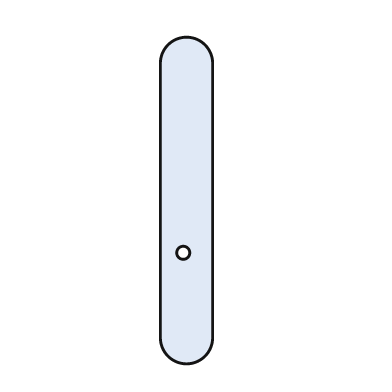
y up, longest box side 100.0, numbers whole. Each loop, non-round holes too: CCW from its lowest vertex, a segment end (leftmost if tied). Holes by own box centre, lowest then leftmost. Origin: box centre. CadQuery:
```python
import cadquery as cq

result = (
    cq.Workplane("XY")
    .moveTo(-8.0, -42.0)
    .threePointArc((0.0, -50.0), (8.0, -42.0))
    .lineTo(8.0, 42.0)
    .threePointArc((0.0, 50.0), (-8.0, 42.0))
    .close()
    .moveTo(-1.0, -16.0)
    .circle(2.0)
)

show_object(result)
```